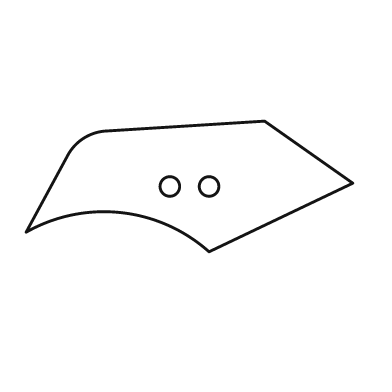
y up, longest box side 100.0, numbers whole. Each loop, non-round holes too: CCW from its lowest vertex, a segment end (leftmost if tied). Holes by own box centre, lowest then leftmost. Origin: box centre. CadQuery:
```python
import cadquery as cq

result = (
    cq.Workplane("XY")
    .moveTo(6.0, -20.0)
    .lineTo(50.0, 1.0)
    .lineTo(23.0, 20.0)
    .lineTo(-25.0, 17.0)
    .threePointArc((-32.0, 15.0), (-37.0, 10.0))
    .lineTo(-50.0, -14.0)
    .threePointArc((-21.0, -8.0), (6.0, -20.0))
    .close()
    .moveTo(-6.0, 0.0)
    .circle(3.0)
    .moveTo(6.0, 0.0)
    .circle(3.0)
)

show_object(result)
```